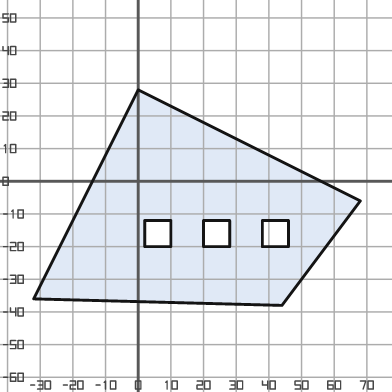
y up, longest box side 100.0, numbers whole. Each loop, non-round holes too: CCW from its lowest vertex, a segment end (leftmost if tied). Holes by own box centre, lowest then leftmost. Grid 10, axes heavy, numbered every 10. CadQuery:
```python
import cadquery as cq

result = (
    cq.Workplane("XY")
    .moveTo(44.0, -38.0)
    .lineTo(68.0, -6.0)
    .lineTo(0.0, 28.0)
    .lineTo(-32.0, -36.0)
    .close()
    .moveTo(2.0, -20.0)
    .lineTo(10.0, -20.0)
    .lineTo(10.0, -12.0)
    .lineTo(2.0, -12.0)
    .close()
    .moveTo(20.0, -20.0)
    .lineTo(28.0, -20.0)
    .lineTo(28.0, -12.0)
    .lineTo(20.0, -12.0)
    .close()
    .moveTo(38.0, -20.0)
    .lineTo(46.0, -20.0)
    .lineTo(46.0, -12.0)
    .lineTo(38.0, -12.0)
    .close()
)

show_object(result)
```